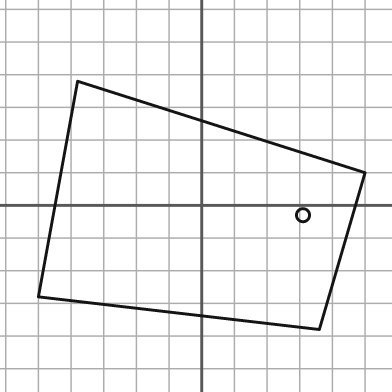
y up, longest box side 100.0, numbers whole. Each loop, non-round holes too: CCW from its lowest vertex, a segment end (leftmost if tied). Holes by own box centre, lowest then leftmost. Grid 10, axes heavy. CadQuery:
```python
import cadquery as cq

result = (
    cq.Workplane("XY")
    .moveTo(36.0, -38.0)
    .lineTo(50.0, 10.0)
    .lineTo(-38.0, 38.0)
    .lineTo(-50.0, -28.0)
    .close()
    .moveTo(31.0, -3.0)
    .circle(2.0)
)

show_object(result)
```